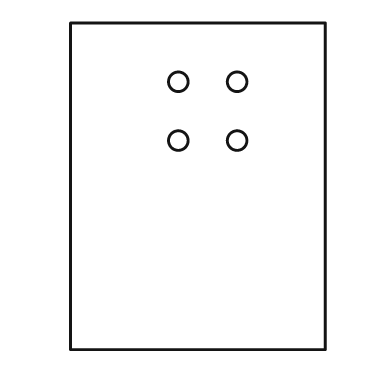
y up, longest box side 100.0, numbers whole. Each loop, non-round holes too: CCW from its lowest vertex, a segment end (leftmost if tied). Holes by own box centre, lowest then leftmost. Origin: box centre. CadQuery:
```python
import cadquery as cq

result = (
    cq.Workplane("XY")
    .moveTo(-39.0, -50.0)
    .lineTo(39.0, -50.0)
    .lineTo(39.0, 50.0)
    .lineTo(-39.0, 50.0)
    .close()
    .moveTo(-6.0, 14.0)
    .circle(3.0)
    .moveTo(12.0, 14.0)
    .circle(3.0)
    .moveTo(-6.0, 32.0)
    .circle(3.0)
    .moveTo(12.0, 32.0)
    .circle(3.0)
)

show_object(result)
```